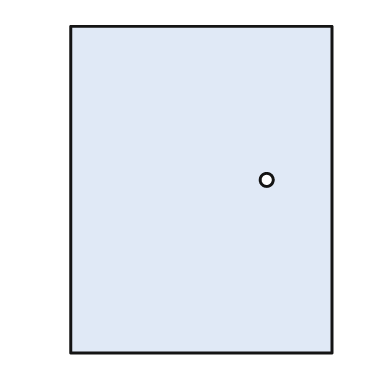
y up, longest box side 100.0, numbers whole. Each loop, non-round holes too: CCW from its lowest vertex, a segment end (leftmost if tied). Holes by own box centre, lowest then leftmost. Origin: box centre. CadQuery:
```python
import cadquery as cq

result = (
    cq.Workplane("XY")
    .moveTo(-40.0, -50.0)
    .lineTo(40.0, -50.0)
    .lineTo(40.0, 50.0)
    .lineTo(-40.0, 50.0)
    .close()
    .moveTo(20.0, 3.0)
    .circle(2.0)
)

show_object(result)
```